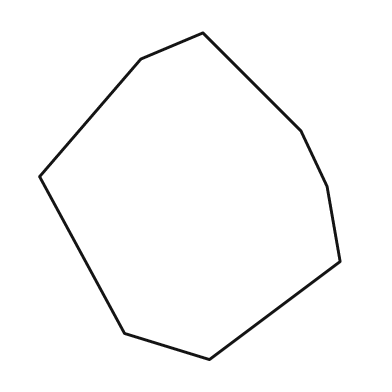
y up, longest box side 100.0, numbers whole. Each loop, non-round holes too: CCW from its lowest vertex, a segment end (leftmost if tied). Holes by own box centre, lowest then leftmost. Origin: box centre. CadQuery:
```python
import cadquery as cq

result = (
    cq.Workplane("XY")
    .moveTo(6.0, -50.0)
    .lineTo(46.0, -20.0)
    .lineTo(42.0, 3.0)
    .lineTo(34.0, 20.0)
    .lineTo(4.0, 50.0)
    .lineTo(-15.0, 42.0)
    .lineTo(-46.0, 6.0)
    .lineTo(-20.0, -42.0)
    .close()
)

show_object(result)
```